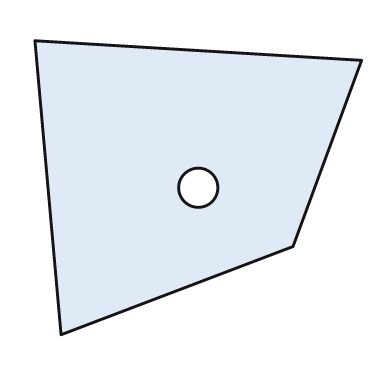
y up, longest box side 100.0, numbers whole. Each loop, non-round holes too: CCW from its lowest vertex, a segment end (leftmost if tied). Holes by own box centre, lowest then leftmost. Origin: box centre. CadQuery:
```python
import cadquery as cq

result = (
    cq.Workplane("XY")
    .moveTo(-42.0, -45.0)
    .lineTo(29.0, -18.0)
    .lineTo(50.0, 39.0)
    .lineTo(-50.0, 45.0)
    .close()
    .moveTo(0.0, 0.0)
    .circle(6.0)
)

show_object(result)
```